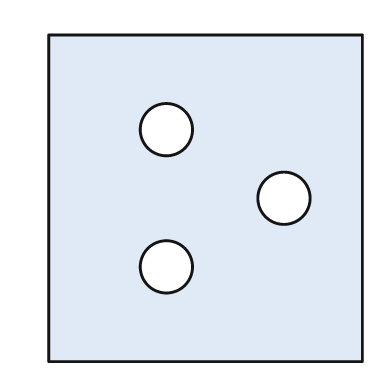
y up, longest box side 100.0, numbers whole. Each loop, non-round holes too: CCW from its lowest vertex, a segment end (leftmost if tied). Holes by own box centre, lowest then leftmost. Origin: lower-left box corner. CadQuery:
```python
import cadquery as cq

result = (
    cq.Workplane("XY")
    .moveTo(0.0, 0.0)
    .lineTo(96.0, 0.0)
    .lineTo(96.0, 100.0)
    .lineTo(0.0, 100.0)
    .close()
    .moveTo(36.0, 29.0)
    .circle(8.0)
    .moveTo(72.0, 50.0)
    .circle(8.0)
    .moveTo(36.0, 71.0)
    .circle(8.0)
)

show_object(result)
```